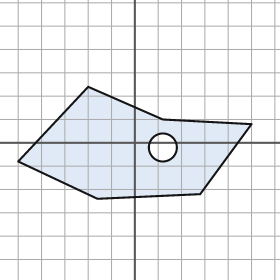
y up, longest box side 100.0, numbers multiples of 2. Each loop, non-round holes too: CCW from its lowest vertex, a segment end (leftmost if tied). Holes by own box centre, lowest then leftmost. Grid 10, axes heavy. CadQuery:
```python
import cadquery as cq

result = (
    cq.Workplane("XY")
    .moveTo(-16.0, -24.0)
    .lineTo(28.0, -22.0)
    .lineTo(50.0, 8.0)
    .lineTo(12.0, 10.0)
    .lineTo(-20.0, 24.0)
    .lineTo(-50.0, -8.0)
    .close()
    .moveTo(12.0, -2.0)
    .circle(6.0)
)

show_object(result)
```